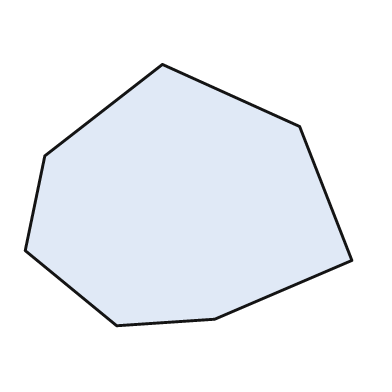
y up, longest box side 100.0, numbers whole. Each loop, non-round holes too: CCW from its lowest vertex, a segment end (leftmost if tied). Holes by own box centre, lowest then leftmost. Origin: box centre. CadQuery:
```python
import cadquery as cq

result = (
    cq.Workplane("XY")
    .moveTo(-22.0, -40.0)
    .lineTo(8.0, -38.0)
    .lineTo(50.0, -20.0)
    .lineTo(34.0, 21.0)
    .lineTo(-8.0, 40.0)
    .lineTo(-44.0, 12.0)
    .lineTo(-50.0, -17.0)
    .close()
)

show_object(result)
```